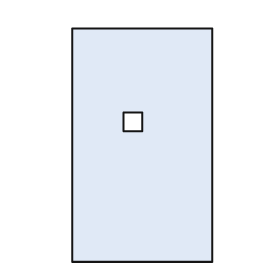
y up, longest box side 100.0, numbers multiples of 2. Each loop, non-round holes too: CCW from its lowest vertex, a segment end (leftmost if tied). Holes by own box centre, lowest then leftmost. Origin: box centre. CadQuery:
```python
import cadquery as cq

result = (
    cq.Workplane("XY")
    .moveTo(-30.0, -50.0)
    .lineTo(30.0, -50.0)
    .lineTo(30.0, 50.0)
    .lineTo(-30.0, 50.0)
    .close()
    .moveTo(-8.0, 6.0)
    .lineTo(0.0, 6.0)
    .lineTo(0.0, 14.0)
    .lineTo(-8.0, 14.0)
    .close()
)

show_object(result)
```